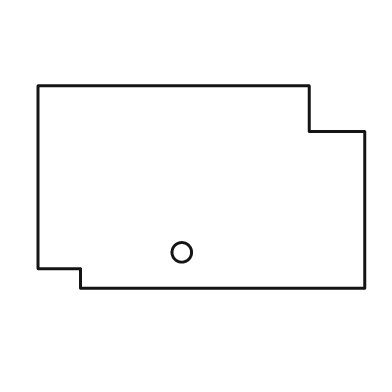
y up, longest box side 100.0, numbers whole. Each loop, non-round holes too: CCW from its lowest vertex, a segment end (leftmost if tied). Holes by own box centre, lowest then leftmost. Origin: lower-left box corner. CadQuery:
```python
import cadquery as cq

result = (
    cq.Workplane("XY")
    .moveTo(13.0, 0.0)
    .lineTo(100.0, 0.0)
    .lineTo(100.0, 48.0)
    .lineTo(83.0, 48.0)
    .lineTo(83.0, 62.0)
    .lineTo(0.0, 62.0)
    .lineTo(0.0, 6.0)
    .lineTo(13.0, 6.0)
    .close()
    .moveTo(44.0, 11.0)
    .circle(3.0)
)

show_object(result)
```